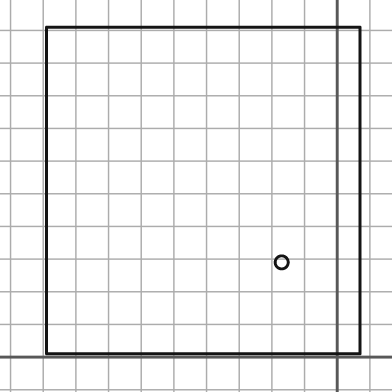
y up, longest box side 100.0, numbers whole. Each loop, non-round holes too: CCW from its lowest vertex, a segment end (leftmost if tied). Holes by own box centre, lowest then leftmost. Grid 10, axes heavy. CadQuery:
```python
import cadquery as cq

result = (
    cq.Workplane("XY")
    .moveTo(-89.0, 1.0)
    .lineTo(7.0, 1.0)
    .lineTo(7.0, 101.0)
    .lineTo(-89.0, 101.0)
    .close()
    .moveTo(-17.0, 29.0)
    .circle(2.0)
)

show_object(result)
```